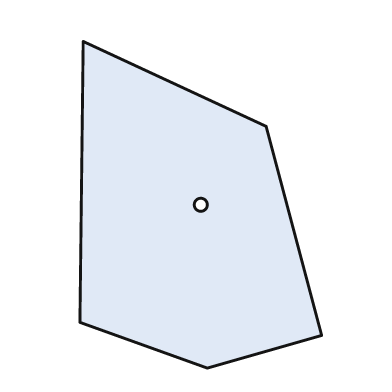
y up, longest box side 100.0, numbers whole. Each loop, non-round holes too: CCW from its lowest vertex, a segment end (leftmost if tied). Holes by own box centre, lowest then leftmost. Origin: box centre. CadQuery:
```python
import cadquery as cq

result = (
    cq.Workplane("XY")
    .moveTo(2.0, -50.0)
    .lineTo(37.0, -40.0)
    .lineTo(20.0, 24.0)
    .lineTo(-36.0, 50.0)
    .lineTo(-37.0, -36.0)
    .close()
    .moveTo(0.0, 0.0)
    .circle(2.0)
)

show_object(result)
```